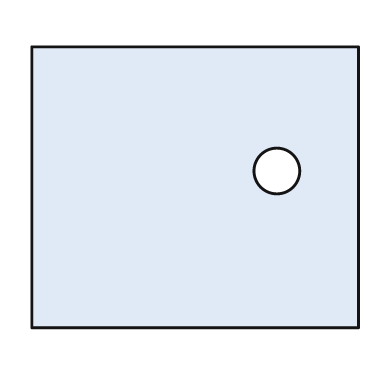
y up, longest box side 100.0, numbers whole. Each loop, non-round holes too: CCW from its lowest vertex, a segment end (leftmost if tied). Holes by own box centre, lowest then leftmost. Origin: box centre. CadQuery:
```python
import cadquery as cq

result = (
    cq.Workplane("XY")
    .moveTo(-50.0, -43.0)
    .lineTo(50.0, -43.0)
    .lineTo(50.0, 43.0)
    .lineTo(-50.0, 43.0)
    .close()
    .moveTo(25.0, 5.0)
    .circle(7.0)
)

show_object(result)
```